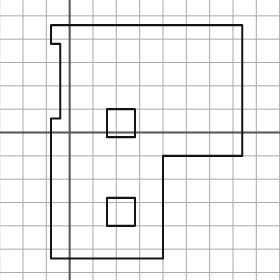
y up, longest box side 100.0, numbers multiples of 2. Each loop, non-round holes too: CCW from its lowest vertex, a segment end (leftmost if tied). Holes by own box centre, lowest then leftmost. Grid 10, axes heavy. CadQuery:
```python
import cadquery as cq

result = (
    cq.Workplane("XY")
    .moveTo(-8.0, -54.0)
    .lineTo(40.0, -54.0)
    .lineTo(40.0, -10.0)
    .lineTo(74.0, -10.0)
    .lineTo(74.0, 46.0)
    .lineTo(-8.0, 46.0)
    .lineTo(-8.0, 38.0)
    .lineTo(-4.0, 38.0)
    .lineTo(-4.0, 6.0)
    .lineTo(-8.0, 6.0)
    .close()
    .moveTo(16.0, -40.0)
    .lineTo(28.0, -40.0)
    .lineTo(28.0, -28.0)
    .lineTo(16.0, -28.0)
    .close()
    .moveTo(16.0, -2.0)
    .lineTo(28.0, -2.0)
    .lineTo(28.0, 10.0)
    .lineTo(16.0, 10.0)
    .close()
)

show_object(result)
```